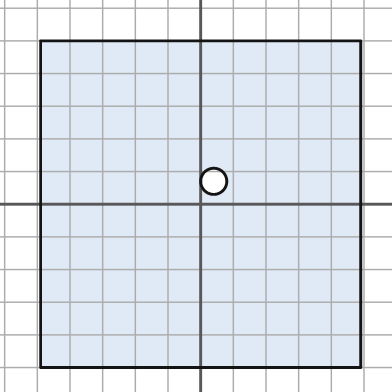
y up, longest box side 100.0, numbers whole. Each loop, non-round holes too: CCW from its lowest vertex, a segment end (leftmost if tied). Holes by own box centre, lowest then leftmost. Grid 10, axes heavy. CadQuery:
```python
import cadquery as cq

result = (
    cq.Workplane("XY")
    .moveTo(-49.0, -50.0)
    .lineTo(49.0, -50.0)
    .lineTo(49.0, 50.0)
    .lineTo(-49.0, 50.0)
    .close()
    .moveTo(4.0, 7.0)
    .circle(4.0)
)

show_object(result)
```